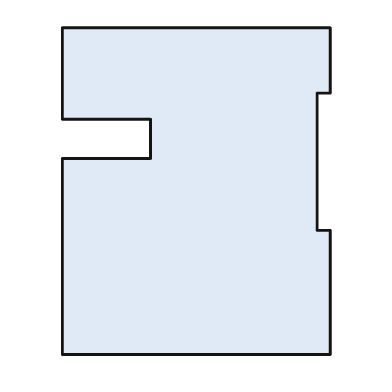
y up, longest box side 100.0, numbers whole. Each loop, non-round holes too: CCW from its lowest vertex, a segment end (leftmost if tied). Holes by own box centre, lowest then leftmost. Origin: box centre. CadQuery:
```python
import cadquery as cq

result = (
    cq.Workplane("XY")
    .moveTo(-41.0, -50.0)
    .lineTo(41.0, -50.0)
    .lineTo(41.0, -12.0)
    .lineTo(37.0, -12.0)
    .lineTo(37.0, 30.0)
    .lineTo(41.0, 30.0)
    .lineTo(41.0, 50.0)
    .lineTo(-41.0, 50.0)
    .lineTo(-41.0, 22.0)
    .lineTo(-14.0, 22.0)
    .lineTo(-14.0, 10.0)
    .lineTo(-41.0, 10.0)
    .close()
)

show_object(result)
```